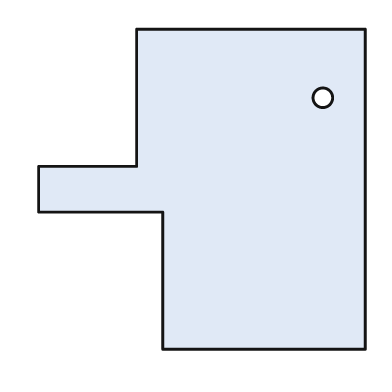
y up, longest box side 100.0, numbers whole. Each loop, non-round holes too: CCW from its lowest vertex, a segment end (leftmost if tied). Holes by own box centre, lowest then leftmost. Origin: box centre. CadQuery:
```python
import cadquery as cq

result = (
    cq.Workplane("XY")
    .moveTo(-12.0, -49.0)
    .lineTo(50.0, -49.0)
    .lineTo(50.0, 49.0)
    .lineTo(-20.0, 49.0)
    .lineTo(-20.0, 7.0)
    .lineTo(-50.0, 7.0)
    .lineTo(-50.0, -7.0)
    .lineTo(-12.0, -7.0)
    .close()
    .moveTo(37.0, 28.0)
    .circle(3.0)
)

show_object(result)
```